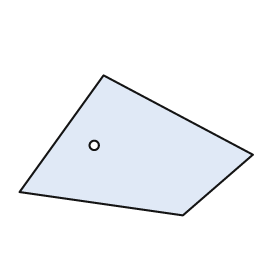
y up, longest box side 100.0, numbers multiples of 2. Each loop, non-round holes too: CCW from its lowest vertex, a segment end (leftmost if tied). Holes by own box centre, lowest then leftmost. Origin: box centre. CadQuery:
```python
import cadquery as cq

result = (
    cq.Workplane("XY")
    .moveTo(20.0, -30.0)
    .lineTo(50.0, -4.0)
    .lineTo(-14.0, 30.0)
    .lineTo(-50.0, -20.0)
    .close()
    .moveTo(-18.0, 0.0)
    .circle(2.0)
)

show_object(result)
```